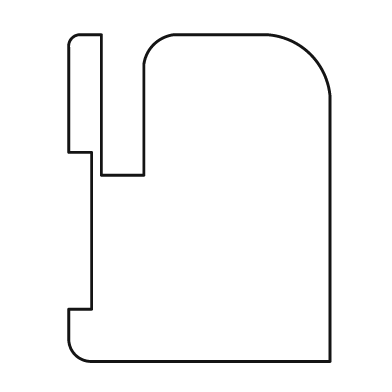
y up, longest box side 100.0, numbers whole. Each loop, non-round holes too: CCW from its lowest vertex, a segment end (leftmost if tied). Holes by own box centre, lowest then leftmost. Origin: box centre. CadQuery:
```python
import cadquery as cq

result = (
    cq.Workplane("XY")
    .moveTo(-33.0, -50.0)
    .lineTo(40.0, -50.0)
    .lineTo(40.0, 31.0)
    .threePointArc((34.0, 44.0), (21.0, 50.0))
    .lineTo(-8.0, 50.0)
    .threePointArc((-14.0, 47.0), (-17.0, 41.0))
    .lineTo(-17.0, 7.0)
    .lineTo(-30.0, 7.0)
    .lineTo(-30.0, 50.0)
    .lineTo(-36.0, 50.0)
    .threePointArc((-39.0, 49.0), (-40.0, 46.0))
    .lineTo(-40.0, 14.0)
    .lineTo(-33.0, 14.0)
    .lineTo(-33.0, -34.0)
    .lineTo(-40.0, -34.0)
    .lineTo(-40.0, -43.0)
    .threePointArc((-38.0, -48.0), (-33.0, -50.0))
    .close()
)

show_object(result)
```